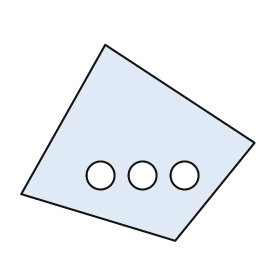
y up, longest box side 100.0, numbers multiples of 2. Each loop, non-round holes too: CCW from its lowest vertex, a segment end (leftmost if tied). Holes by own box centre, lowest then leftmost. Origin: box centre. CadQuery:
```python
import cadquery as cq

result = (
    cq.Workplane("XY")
    .moveTo(16.0, -42.0)
    .lineTo(50.0, 0.0)
    .lineTo(-14.0, 42.0)
    .lineTo(-50.0, -22.0)
    .close()
    .moveTo(-16.0, -14.0)
    .circle(6.0)
    .moveTo(2.0, -14.0)
    .circle(6.0)
    .moveTo(20.0, -14.0)
    .circle(6.0)
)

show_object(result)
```